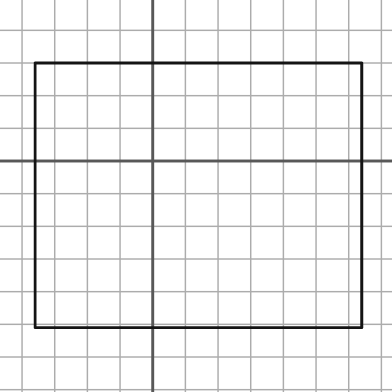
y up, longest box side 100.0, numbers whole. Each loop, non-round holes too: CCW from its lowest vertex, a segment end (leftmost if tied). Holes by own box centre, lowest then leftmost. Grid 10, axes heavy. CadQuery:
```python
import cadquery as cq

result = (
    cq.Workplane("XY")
    .moveTo(-36.0, -51.0)
    .lineTo(64.0, -51.0)
    .lineTo(64.0, 30.0)
    .lineTo(-36.0, 30.0)
    .close()
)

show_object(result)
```